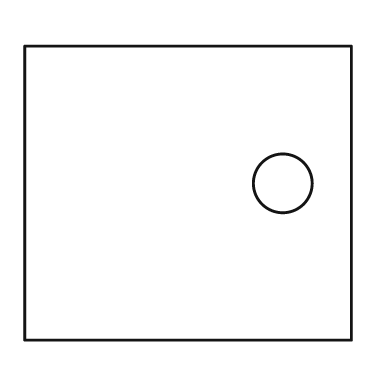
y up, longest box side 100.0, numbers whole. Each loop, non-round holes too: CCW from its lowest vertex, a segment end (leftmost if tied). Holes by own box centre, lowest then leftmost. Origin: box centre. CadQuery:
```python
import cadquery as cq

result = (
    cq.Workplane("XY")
    .moveTo(-50.0, -45.0)
    .lineTo(50.0, -45.0)
    .lineTo(50.0, 45.0)
    .lineTo(-50.0, 45.0)
    .close()
    .moveTo(29.0, 3.0)
    .circle(9.0)
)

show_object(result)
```